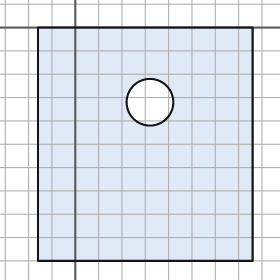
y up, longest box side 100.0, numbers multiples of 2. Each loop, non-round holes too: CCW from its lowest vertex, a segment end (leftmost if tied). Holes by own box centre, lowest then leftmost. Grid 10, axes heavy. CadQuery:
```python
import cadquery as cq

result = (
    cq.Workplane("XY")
    .moveTo(-16.0, -100.0)
    .lineTo(76.0, -100.0)
    .lineTo(76.0, 0.0)
    .lineTo(-16.0, 0.0)
    .close()
    .moveTo(32.0, -32.0)
    .circle(10.0)
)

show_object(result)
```